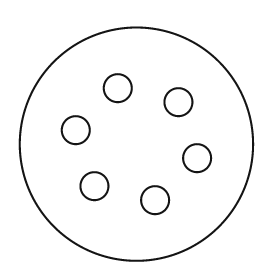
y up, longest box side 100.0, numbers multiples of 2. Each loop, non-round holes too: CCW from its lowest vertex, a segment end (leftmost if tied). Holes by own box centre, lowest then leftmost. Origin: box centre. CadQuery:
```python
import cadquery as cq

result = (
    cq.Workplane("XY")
    .moveTo(0.0, 0.0)
    .circle(50.0)
    .moveTo(8.0, -24.0)
    .circle(6.0)
    .moveTo(-18.0, -18.0)
    .circle(6.0)
    .moveTo(26.0, -6.0)
    .circle(6.0)
    .moveTo(-26.0, 6.0)
    .circle(6.0)
    .moveTo(18.0, 18.0)
    .circle(6.0)
    .moveTo(-8.0, 24.0)
    .circle(6.0)
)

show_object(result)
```